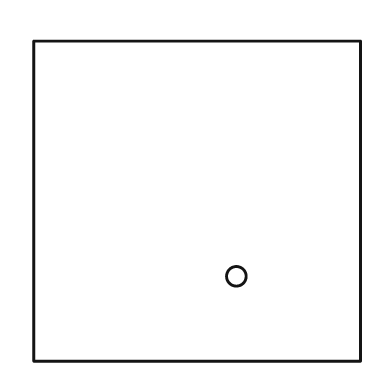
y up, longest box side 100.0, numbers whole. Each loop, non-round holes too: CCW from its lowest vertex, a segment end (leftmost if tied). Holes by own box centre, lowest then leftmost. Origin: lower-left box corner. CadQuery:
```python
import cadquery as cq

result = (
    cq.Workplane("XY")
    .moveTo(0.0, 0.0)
    .lineTo(100.0, 0.0)
    .lineTo(100.0, 98.0)
    .lineTo(0.0, 98.0)
    .close()
    .moveTo(62.0, 26.0)
    .circle(3.0)
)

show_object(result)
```